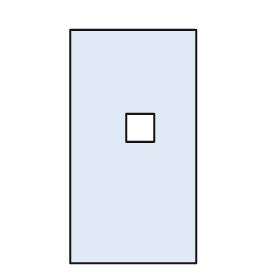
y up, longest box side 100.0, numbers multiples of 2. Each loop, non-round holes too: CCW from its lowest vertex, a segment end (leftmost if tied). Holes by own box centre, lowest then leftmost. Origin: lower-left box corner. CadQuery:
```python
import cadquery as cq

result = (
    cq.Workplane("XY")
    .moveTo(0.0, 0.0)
    .lineTo(54.0, 0.0)
    .lineTo(54.0, 100.0)
    .lineTo(0.0, 100.0)
    .close()
    .moveTo(24.0, 52.0)
    .lineTo(36.0, 52.0)
    .lineTo(36.0, 64.0)
    .lineTo(24.0, 64.0)
    .close()
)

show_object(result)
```